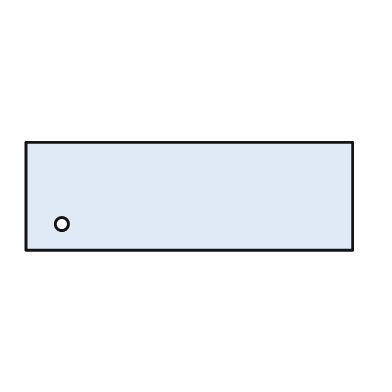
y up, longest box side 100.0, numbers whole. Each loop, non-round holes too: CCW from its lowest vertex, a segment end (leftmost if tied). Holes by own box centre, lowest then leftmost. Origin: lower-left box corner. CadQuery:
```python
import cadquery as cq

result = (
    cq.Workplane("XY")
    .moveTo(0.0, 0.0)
    .lineTo(100.0, 0.0)
    .lineTo(100.0, 33.0)
    .lineTo(0.0, 33.0)
    .close()
    .moveTo(11.0, 8.0)
    .circle(2.0)
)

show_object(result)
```